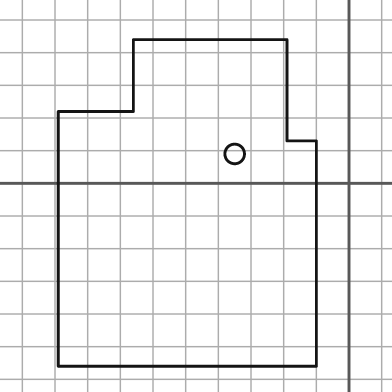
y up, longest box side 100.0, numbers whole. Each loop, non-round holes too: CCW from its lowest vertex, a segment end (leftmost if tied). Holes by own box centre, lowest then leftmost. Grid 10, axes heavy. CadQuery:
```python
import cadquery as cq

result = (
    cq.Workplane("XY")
    .moveTo(-89.0, -56.0)
    .lineTo(-10.0, -56.0)
    .lineTo(-10.0, 13.0)
    .lineTo(-19.0, 13.0)
    .lineTo(-19.0, 44.0)
    .lineTo(-66.0, 44.0)
    .lineTo(-66.0, 22.0)
    .lineTo(-89.0, 22.0)
    .close()
    .moveTo(-35.0, 9.0)
    .circle(3.0)
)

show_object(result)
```